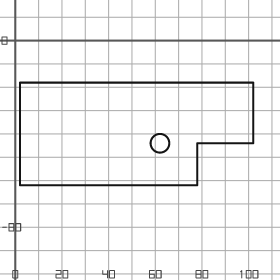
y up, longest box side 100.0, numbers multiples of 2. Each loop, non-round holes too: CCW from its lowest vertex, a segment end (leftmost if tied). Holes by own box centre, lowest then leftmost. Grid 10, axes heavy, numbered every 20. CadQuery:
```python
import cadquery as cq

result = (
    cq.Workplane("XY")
    .moveTo(2.0, -62.0)
    .lineTo(78.0, -62.0)
    .lineTo(78.0, -44.0)
    .lineTo(102.0, -44.0)
    .lineTo(102.0, -18.0)
    .lineTo(2.0, -18.0)
    .close()
    .moveTo(62.0, -44.0)
    .circle(4.0)
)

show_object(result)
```